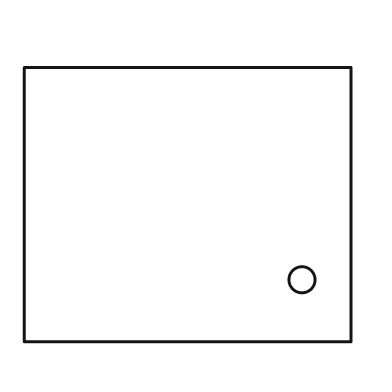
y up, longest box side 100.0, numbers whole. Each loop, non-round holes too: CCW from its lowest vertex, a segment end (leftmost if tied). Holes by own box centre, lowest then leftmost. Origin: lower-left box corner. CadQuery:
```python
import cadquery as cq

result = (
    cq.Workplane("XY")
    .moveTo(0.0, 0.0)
    .lineTo(100.0, 0.0)
    .lineTo(100.0, 84.0)
    .lineTo(0.0, 84.0)
    .close()
    .moveTo(85.0, 19.0)
    .circle(4.0)
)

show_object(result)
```